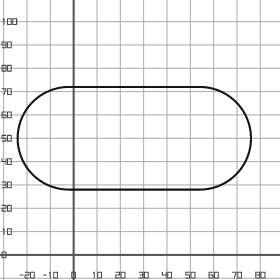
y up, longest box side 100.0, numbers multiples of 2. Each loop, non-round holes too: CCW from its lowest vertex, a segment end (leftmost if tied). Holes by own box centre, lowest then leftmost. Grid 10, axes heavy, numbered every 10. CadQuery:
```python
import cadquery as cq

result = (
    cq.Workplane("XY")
    .moveTo(-2.0, 28.0)
    .lineTo(54.0, 28.0)
    .threePointArc((76.0, 50.0), (54.0, 72.0))
    .lineTo(-2.0, 72.0)
    .threePointArc((-24.0, 50.0), (-2.0, 28.0))
    .close()
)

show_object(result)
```